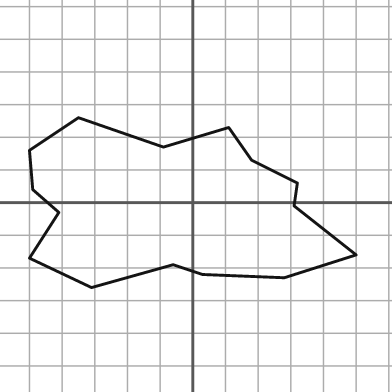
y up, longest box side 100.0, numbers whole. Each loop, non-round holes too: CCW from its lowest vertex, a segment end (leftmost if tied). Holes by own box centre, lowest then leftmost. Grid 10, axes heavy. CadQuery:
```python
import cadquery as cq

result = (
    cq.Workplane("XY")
    .moveTo(-31.0, -26.0)
    .lineTo(-6.0, -19.0)
    .lineTo(3.0, -22.0)
    .lineTo(28.0, -23.0)
    .lineTo(50.0, -16.0)
    .lineTo(31.0, -1.0)
    .lineTo(32.0, 6.0)
    .lineTo(18.0, 13.0)
    .lineTo(11.0, 23.0)
    .lineTo(-9.0, 17.0)
    .lineTo(-35.0, 26.0)
    .lineTo(-50.0, 16.0)
    .lineTo(-49.0, 4.0)
    .lineTo(-41.0, -3.0)
    .lineTo(-50.0, -17.0)
    .close()
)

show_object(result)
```